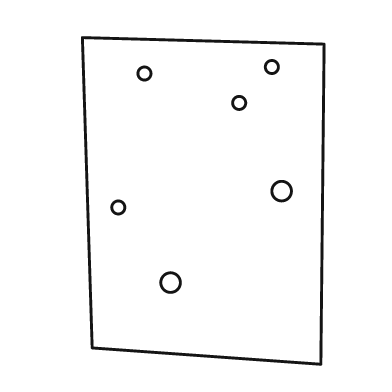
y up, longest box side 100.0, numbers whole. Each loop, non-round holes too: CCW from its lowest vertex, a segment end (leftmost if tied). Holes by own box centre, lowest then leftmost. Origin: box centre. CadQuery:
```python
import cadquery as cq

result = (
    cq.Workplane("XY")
    .moveTo(36.0, -50.0)
    .lineTo(37.0, 48.0)
    .lineTo(-37.0, 50.0)
    .lineTo(-34.0, -45.0)
    .close()
    .moveTo(-10.0, -25.0)
    .circle(3.0)
    .moveTo(-26.0, -2.0)
    .circle(2.0)
    .moveTo(24.0, 3.0)
    .circle(3.0)
    .moveTo(11.0, 30.0)
    .circle(2.0)
    .moveTo(-18.0, 39.0)
    .circle(2.0)
    .moveTo(21.0, 41.0)
    .circle(2.0)
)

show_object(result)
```